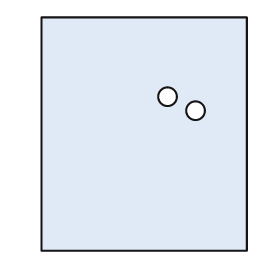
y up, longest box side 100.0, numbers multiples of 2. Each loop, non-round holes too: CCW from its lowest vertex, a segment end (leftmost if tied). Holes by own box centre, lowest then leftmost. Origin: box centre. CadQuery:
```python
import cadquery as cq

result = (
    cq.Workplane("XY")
    .moveTo(-44.0, -50.0)
    .lineTo(44.0, -50.0)
    .lineTo(44.0, 50.0)
    .lineTo(-44.0, 50.0)
    .close()
    .moveTo(22.0, 10.0)
    .circle(4.0)
    .moveTo(10.0, 16.0)
    .circle(4.0)
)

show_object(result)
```